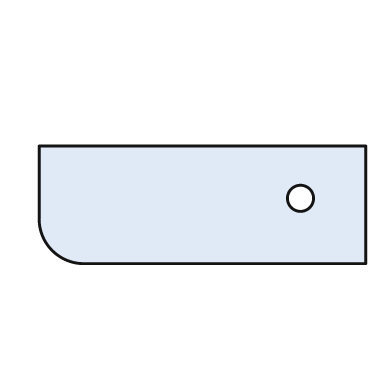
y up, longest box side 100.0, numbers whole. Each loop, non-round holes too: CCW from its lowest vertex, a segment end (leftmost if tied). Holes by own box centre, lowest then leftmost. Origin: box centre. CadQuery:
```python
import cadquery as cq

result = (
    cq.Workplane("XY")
    .moveTo(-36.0, -18.0)
    .lineTo(50.0, -18.0)
    .lineTo(50.0, 18.0)
    .lineTo(-50.0, 18.0)
    .lineTo(-50.0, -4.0)
    .threePointArc((-46.0, -14.0), (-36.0, -18.0))
    .close()
    .moveTo(30.0, 2.0)
    .circle(4.0)
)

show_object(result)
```